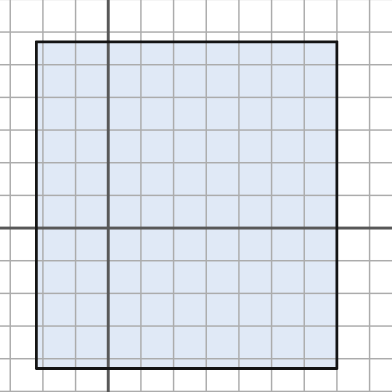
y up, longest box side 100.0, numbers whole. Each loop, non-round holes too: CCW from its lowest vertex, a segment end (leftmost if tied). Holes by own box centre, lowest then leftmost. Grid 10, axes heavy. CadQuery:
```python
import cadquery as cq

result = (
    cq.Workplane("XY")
    .moveTo(-22.0, -43.0)
    .lineTo(70.0, -43.0)
    .lineTo(70.0, 57.0)
    .lineTo(-22.0, 57.0)
    .close()
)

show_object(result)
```